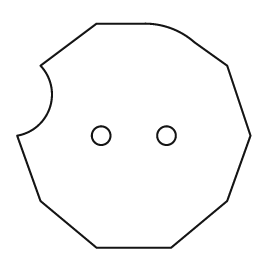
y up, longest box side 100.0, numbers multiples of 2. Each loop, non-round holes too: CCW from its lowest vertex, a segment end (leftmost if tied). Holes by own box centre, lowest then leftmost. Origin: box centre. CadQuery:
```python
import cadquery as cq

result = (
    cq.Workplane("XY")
    .moveTo(-16.0, -48.0)
    .lineTo(16.0, -48.0)
    .lineTo(40.0, -28.0)
    .lineTo(50.0, 0.0)
    .lineTo(40.0, 30.0)
    .lineTo(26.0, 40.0)
    .threePointArc((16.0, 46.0), (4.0, 48.0))
    .lineTo(-16.0, 48.0)
    .lineTo(-40.0, 30.0)
    .threePointArc((-36.0, 12.0), (-50.0, 0.0))
    .lineTo(-40.0, -28.0)
    .close()
    .moveTo(-14.0, 0.0)
    .circle(4.0)
    .moveTo(14.0, 0.0)
    .circle(4.0)
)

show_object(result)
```